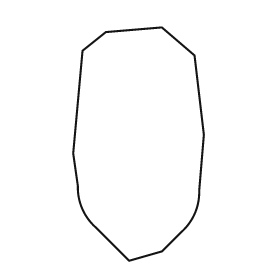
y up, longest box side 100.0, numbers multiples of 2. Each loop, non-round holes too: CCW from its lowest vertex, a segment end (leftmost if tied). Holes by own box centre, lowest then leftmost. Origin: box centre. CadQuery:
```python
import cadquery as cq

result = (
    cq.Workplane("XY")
    .moveTo(-4.0, -50.0)
    .lineTo(10.0, -46.0)
    .lineTo(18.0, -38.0)
    .threePointArc((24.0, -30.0), (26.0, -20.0))
    .lineTo(28.0, 4.0)
    .lineTo(24.0, 38.0)
    .lineTo(10.0, 50.0)
    .lineTo(-14.0, 48.0)
    .lineTo(-24.0, 40.0)
    .lineTo(-28.0, -4.0)
    .lineTo(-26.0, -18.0)
    .threePointArc((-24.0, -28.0), (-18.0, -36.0))
    .close()
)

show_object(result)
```